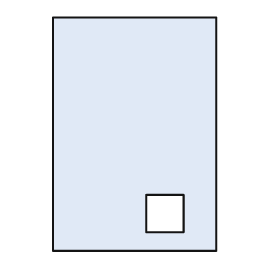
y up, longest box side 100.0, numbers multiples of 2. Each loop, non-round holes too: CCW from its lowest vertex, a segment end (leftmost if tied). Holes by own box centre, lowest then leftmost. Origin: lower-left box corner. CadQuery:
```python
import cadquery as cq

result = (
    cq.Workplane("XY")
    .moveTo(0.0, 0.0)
    .lineTo(70.0, 0.0)
    .lineTo(70.0, 100.0)
    .lineTo(0.0, 100.0)
    .close()
    .moveTo(40.0, 8.0)
    .lineTo(56.0, 8.0)
    .lineTo(56.0, 24.0)
    .lineTo(40.0, 24.0)
    .close()
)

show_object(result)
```